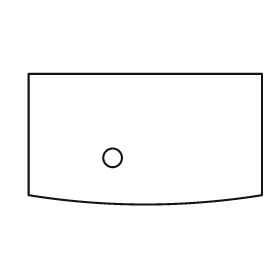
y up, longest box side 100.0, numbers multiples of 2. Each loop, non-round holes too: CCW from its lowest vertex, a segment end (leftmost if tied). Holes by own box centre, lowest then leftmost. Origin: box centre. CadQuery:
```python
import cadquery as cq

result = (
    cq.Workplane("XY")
    .moveTo(-50.0, -24.0)
    .threePointArc((0.0, -28.0), (50.0, -24.0))
    .lineTo(50.0, 28.0)
    .lineTo(-50.0, 28.0)
    .close()
    .moveTo(-14.0, -8.0)
    .circle(4.0)
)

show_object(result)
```